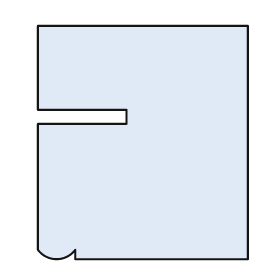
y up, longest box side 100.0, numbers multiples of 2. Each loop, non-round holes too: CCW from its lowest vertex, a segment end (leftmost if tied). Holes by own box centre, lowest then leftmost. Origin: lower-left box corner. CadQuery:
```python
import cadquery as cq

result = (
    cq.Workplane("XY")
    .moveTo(16.0, 0.0)
    .lineTo(90.0, 0.0)
    .lineTo(90.0, 100.0)
    .lineTo(0.0, 100.0)
    .lineTo(0.0, 64.0)
    .lineTo(38.0, 64.0)
    .lineTo(38.0, 58.0)
    .lineTo(0.0, 58.0)
    .lineTo(0.0, 4.0)
    .threePointArc((8.0, 0.0), (16.0, 4.0))
    .close()
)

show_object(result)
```